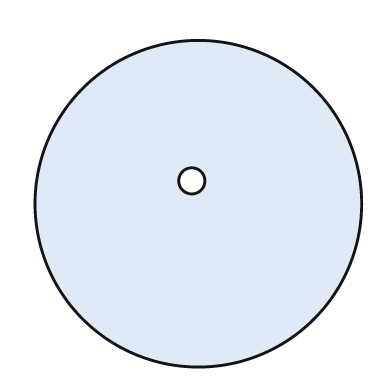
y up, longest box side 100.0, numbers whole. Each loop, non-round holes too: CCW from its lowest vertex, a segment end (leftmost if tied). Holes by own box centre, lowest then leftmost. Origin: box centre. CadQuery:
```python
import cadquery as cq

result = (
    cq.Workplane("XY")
    .moveTo(0.0, 0.0)
    .circle(50.0)
    .moveTo(-2.0, 7.0)
    .circle(4.0)
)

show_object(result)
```